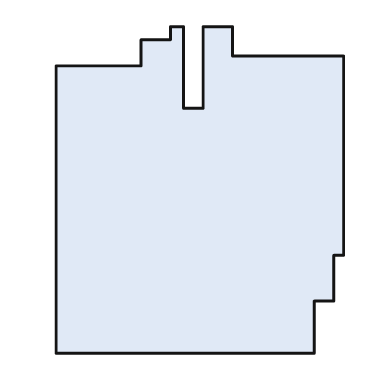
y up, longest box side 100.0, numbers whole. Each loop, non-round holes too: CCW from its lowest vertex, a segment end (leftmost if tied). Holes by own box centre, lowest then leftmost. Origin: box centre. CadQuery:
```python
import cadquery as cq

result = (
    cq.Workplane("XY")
    .moveTo(-44.0, -50.0)
    .lineTo(35.0, -50.0)
    .lineTo(35.0, -34.0)
    .lineTo(41.0, -34.0)
    .lineTo(41.0, -20.0)
    .lineTo(44.0, -20.0)
    .lineTo(44.0, 41.0)
    .lineTo(10.0, 41.0)
    .lineTo(10.0, 50.0)
    .lineTo(1.0, 50.0)
    .lineTo(1.0, 25.0)
    .lineTo(-5.0, 25.0)
    .lineTo(-5.0, 50.0)
    .lineTo(-9.0, 50.0)
    .lineTo(-9.0, 46.0)
    .lineTo(-18.0, 46.0)
    .lineTo(-18.0, 38.0)
    .lineTo(-44.0, 38.0)
    .close()
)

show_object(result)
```